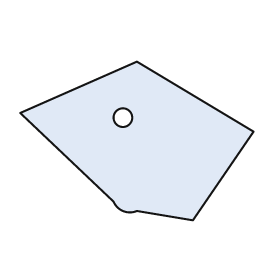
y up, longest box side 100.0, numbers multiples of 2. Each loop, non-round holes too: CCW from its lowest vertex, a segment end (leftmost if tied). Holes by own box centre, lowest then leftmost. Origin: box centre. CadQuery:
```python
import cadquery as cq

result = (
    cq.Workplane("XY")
    .moveTo(24.0, -34.0)
    .lineTo(50.0, 4.0)
    .lineTo(0.0, 34.0)
    .lineTo(-50.0, 12.0)
    .lineTo(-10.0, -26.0)
    .threePointArc((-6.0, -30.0), (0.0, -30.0))
    .close()
    .moveTo(-6.0, 10.0)
    .circle(4.0)
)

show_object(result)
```